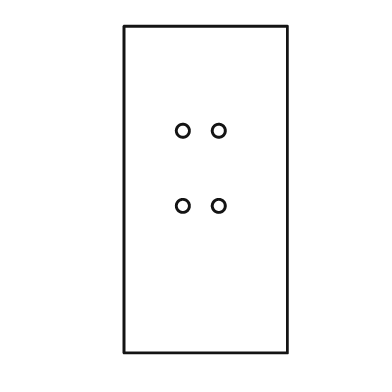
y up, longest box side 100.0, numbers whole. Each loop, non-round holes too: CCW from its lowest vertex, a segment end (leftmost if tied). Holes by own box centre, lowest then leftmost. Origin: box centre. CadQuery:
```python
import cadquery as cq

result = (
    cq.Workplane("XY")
    .moveTo(-25.0, -50.0)
    .lineTo(25.0, -50.0)
    .lineTo(25.0, 50.0)
    .lineTo(-25.0, 50.0)
    .close()
    .moveTo(-7.0, -5.0)
    .circle(2.0)
    .moveTo(4.0, -5.0)
    .circle(2.0)
    .moveTo(-7.0, 18.0)
    .circle(2.0)
    .moveTo(4.0, 18.0)
    .circle(2.0)
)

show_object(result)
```